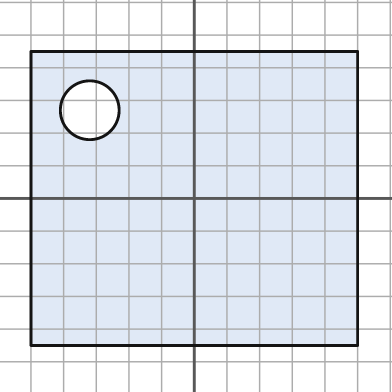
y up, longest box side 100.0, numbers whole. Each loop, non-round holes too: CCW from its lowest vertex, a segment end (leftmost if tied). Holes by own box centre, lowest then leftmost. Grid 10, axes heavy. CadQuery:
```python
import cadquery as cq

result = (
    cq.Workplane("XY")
    .moveTo(-50.0, -45.0)
    .lineTo(50.0, -45.0)
    .lineTo(50.0, 45.0)
    .lineTo(-50.0, 45.0)
    .close()
    .moveTo(-32.0, 27.0)
    .circle(9.0)
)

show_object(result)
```